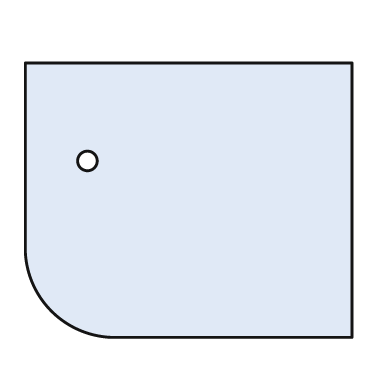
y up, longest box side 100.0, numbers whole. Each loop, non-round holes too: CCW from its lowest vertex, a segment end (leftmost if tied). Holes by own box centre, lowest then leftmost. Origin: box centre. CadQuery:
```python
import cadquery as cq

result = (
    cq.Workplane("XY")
    .moveTo(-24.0, -42.0)
    .lineTo(50.0, -42.0)
    .lineTo(50.0, 42.0)
    .lineTo(-50.0, 42.0)
    .lineTo(-50.0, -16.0)
    .threePointArc((-42.0, -34.0), (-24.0, -42.0))
    .close()
    .moveTo(-31.0, 12.0)
    .circle(3.0)
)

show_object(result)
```